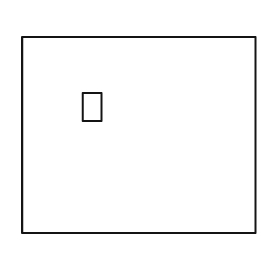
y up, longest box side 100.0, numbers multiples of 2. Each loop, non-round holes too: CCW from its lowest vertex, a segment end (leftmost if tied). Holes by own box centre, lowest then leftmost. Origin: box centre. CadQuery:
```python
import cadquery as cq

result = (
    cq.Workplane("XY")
    .moveTo(-50.0, -42.0)
    .lineTo(50.0, -42.0)
    .lineTo(50.0, 42.0)
    .lineTo(-50.0, 42.0)
    .close()
    .moveTo(-24.0, 6.0)
    .lineTo(-16.0, 6.0)
    .lineTo(-16.0, 18.0)
    .lineTo(-24.0, 18.0)
    .close()
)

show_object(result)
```